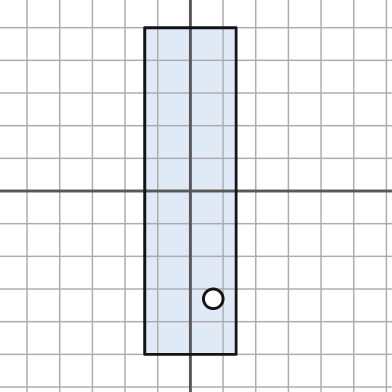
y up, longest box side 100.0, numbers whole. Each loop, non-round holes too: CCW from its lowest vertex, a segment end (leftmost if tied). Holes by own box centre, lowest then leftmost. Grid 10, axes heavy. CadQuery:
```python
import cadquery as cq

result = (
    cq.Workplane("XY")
    .moveTo(-14.0, -50.0)
    .lineTo(14.0, -50.0)
    .lineTo(14.0, 50.0)
    .lineTo(-14.0, 50.0)
    .close()
    .moveTo(7.0, -33.0)
    .circle(3.0)
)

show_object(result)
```